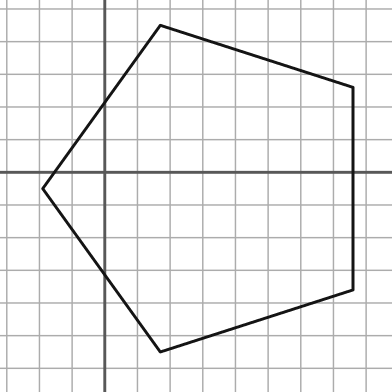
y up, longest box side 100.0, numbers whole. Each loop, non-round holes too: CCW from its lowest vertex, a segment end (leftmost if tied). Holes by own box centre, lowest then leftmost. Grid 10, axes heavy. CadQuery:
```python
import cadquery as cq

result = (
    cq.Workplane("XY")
    .moveTo(17.0, -55.0)
    .lineTo(76.0, -36.0)
    .lineTo(76.0, 26.0)
    .lineTo(17.0, 45.0)
    .lineTo(-19.0, -5.0)
    .close()
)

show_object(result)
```